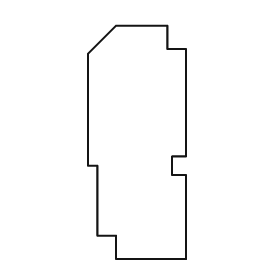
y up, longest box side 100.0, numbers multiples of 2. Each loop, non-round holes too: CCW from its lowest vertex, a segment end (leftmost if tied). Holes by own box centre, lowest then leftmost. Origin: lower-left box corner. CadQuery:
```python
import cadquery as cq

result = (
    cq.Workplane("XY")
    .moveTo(12.0, 0.0)
    .lineTo(42.0, 0.0)
    .lineTo(42.0, 36.0)
    .lineTo(36.0, 36.0)
    .lineTo(36.0, 44.0)
    .lineTo(42.0, 44.0)
    .lineTo(42.0, 90.0)
    .lineTo(34.0, 90.0)
    .lineTo(34.0, 100.0)
    .lineTo(12.0, 100.0)
    .lineTo(0.0, 88.0)
    .lineTo(0.0, 40.0)
    .lineTo(4.0, 40.0)
    .lineTo(4.0, 10.0)
    .lineTo(12.0, 10.0)
    .close()
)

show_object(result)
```